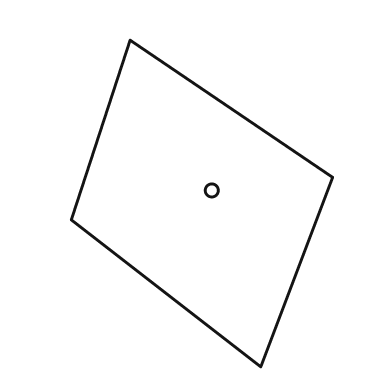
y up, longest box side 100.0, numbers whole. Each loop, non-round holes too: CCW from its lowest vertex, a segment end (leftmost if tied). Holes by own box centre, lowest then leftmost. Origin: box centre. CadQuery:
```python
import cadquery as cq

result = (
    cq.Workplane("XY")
    .moveTo(18.0, -50.0)
    .lineTo(40.0, 8.0)
    .lineTo(-22.0, 50.0)
    .lineTo(-40.0, -5.0)
    .close()
    .moveTo(3.0, 4.0)
    .circle(2.0)
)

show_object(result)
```